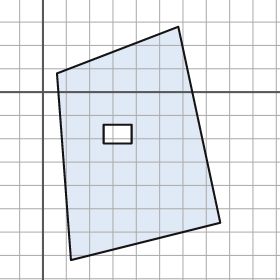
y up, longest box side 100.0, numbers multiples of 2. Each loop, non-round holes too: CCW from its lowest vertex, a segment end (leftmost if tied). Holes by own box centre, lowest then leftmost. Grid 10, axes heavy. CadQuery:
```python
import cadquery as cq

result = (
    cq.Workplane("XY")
    .moveTo(12.0, -72.0)
    .lineTo(76.0, -56.0)
    .lineTo(58.0, 28.0)
    .lineTo(6.0, 8.0)
    .close()
    .moveTo(26.0, -22.0)
    .lineTo(38.0, -22.0)
    .lineTo(38.0, -14.0)
    .lineTo(26.0, -14.0)
    .close()
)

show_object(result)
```